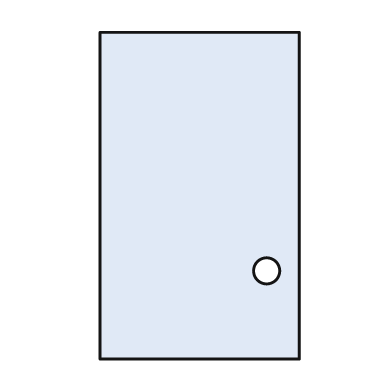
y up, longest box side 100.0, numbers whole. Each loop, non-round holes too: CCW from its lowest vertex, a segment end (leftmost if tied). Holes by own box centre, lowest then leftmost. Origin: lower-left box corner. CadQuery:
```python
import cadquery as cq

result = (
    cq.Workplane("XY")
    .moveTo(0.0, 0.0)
    .lineTo(61.0, 0.0)
    .lineTo(61.0, 100.0)
    .lineTo(0.0, 100.0)
    .close()
    .moveTo(51.0, 27.0)
    .circle(4.0)
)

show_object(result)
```